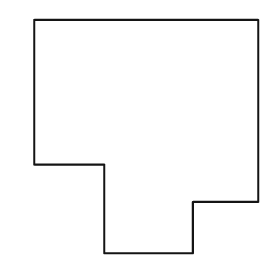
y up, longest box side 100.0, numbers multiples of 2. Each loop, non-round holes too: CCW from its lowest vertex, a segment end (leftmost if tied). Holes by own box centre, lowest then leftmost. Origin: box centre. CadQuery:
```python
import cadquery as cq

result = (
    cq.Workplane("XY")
    .moveTo(-18.0, -50.0)
    .lineTo(20.0, -50.0)
    .lineTo(20.0, -28.0)
    .lineTo(48.0, -28.0)
    .lineTo(48.0, 50.0)
    .lineTo(-48.0, 50.0)
    .lineTo(-48.0, -12.0)
    .lineTo(-18.0, -12.0)
    .close()
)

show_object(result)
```